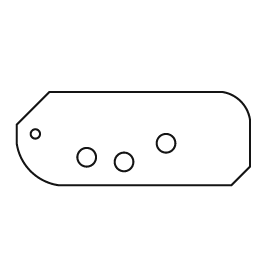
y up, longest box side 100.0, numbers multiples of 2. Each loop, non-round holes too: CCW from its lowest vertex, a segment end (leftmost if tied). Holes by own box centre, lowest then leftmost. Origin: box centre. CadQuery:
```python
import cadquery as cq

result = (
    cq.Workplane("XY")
    .moveTo(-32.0, -20.0)
    .lineTo(42.0, -20.0)
    .lineTo(50.0, -12.0)
    .lineTo(50.0, 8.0)
    .threePointArc((46.0, 16.0), (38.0, 20.0))
    .lineTo(-36.0, 20.0)
    .lineTo(-50.0, 6.0)
    .lineTo(-50.0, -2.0)
    .threePointArc((-44.0, -14.0), (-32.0, -20.0))
    .close()
    .moveTo(-4.0, -10.0)
    .circle(4.0)
    .moveTo(-20.0, -8.0)
    .circle(4.0)
    .moveTo(14.0, -2.0)
    .circle(4.0)
    .moveTo(-42.0, 2.0)
    .circle(2.0)
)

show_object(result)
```